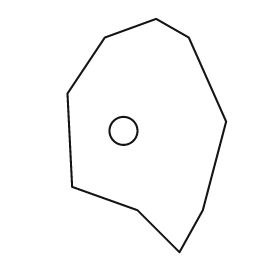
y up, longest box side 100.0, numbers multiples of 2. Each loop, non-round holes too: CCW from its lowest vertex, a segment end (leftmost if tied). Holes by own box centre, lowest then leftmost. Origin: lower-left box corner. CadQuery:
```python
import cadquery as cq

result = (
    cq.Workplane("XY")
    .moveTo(48.0, 0.0)
    .lineTo(58.0, 18.0)
    .lineTo(68.0, 56.0)
    .lineTo(52.0, 92.0)
    .lineTo(38.0, 100.0)
    .lineTo(16.0, 92.0)
    .lineTo(0.0, 68.0)
    .lineTo(2.0, 28.0)
    .lineTo(30.0, 18.0)
    .close()
    .moveTo(24.0, 52.0)
    .circle(6.0)
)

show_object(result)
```